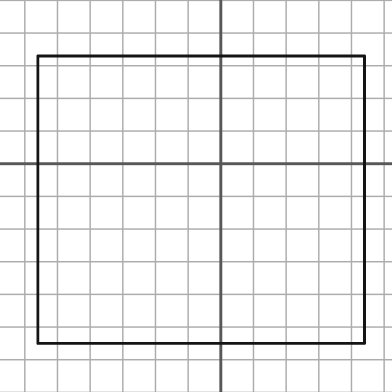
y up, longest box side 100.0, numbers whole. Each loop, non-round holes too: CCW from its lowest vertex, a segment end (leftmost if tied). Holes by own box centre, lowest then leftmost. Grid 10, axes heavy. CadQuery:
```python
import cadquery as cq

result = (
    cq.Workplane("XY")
    .moveTo(-56.0, -55.0)
    .lineTo(44.0, -55.0)
    .lineTo(44.0, 33.0)
    .lineTo(-56.0, 33.0)
    .close()
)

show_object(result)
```